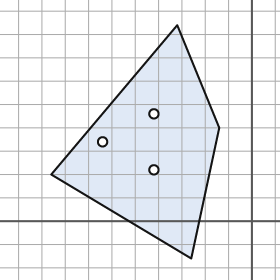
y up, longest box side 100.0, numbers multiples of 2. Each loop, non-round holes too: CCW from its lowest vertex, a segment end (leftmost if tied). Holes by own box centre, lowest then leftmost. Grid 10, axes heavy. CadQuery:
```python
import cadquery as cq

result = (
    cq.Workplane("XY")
    .moveTo(-26.0, -16.0)
    .lineTo(-14.0, 40.0)
    .lineTo(-32.0, 84.0)
    .lineTo(-86.0, 20.0)
    .close()
    .moveTo(-42.0, 22.0)
    .circle(2.0)
    .moveTo(-64.0, 34.0)
    .circle(2.0)
    .moveTo(-42.0, 46.0)
    .circle(2.0)
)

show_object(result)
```